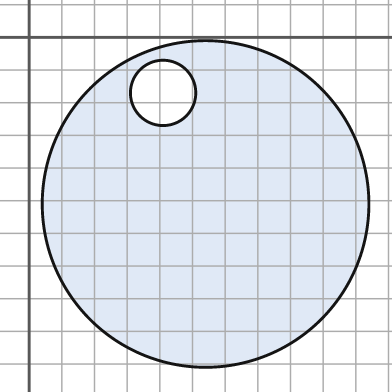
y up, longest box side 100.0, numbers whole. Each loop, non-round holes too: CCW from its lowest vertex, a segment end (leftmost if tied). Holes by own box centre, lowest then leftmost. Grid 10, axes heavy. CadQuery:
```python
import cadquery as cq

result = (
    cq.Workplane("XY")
    .moveTo(54.0, -51.0)
    .circle(50.0)
    .moveTo(41.0, -17.0)
    .circle(10.0)
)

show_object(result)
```